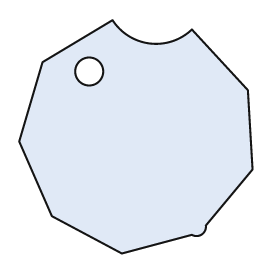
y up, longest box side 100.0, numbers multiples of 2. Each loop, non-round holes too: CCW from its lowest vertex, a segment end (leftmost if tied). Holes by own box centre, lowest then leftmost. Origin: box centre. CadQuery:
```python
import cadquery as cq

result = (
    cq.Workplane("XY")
    .moveTo(-6.0, -50.0)
    .lineTo(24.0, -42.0)
    .threePointArc((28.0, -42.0), (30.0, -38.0))
    .lineTo(50.0, -14.0)
    .lineTo(48.0, 20.0)
    .lineTo(24.0, 46.0)
    .threePointArc((6.0, 40.0), (-10.0, 50.0))
    .lineTo(-40.0, 32.0)
    .lineTo(-50.0, -2.0)
    .lineTo(-36.0, -34.0)
    .close()
    .moveTo(-20.0, 28.0)
    .circle(6.0)
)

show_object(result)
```